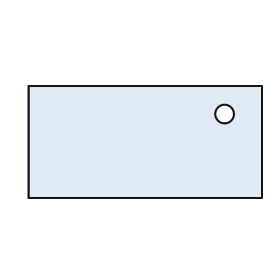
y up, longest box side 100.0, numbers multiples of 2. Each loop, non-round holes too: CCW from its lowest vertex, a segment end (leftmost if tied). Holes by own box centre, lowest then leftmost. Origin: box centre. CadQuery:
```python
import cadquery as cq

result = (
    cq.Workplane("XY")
    .moveTo(-50.0, -24.0)
    .lineTo(50.0, -24.0)
    .lineTo(50.0, 24.0)
    .lineTo(-50.0, 24.0)
    .close()
    .moveTo(34.0, 12.0)
    .circle(4.0)
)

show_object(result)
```